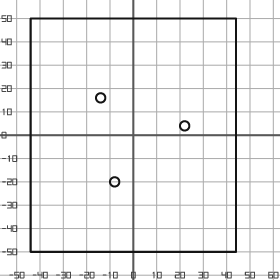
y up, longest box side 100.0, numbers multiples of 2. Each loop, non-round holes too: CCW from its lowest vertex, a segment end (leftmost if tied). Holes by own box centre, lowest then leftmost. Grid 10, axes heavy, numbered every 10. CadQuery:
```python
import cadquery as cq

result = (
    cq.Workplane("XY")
    .moveTo(-44.0, -50.0)
    .lineTo(44.0, -50.0)
    .lineTo(44.0, 50.0)
    .lineTo(-44.0, 50.0)
    .close()
    .moveTo(-8.0, -20.0)
    .circle(2.0)
    .moveTo(22.0, 4.0)
    .circle(2.0)
    .moveTo(-14.0, 16.0)
    .circle(2.0)
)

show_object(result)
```